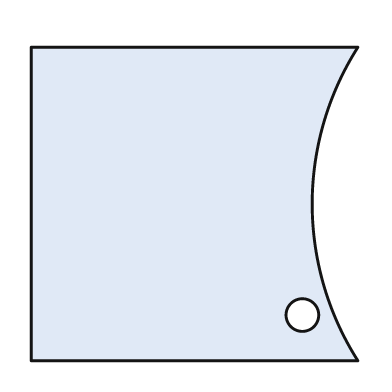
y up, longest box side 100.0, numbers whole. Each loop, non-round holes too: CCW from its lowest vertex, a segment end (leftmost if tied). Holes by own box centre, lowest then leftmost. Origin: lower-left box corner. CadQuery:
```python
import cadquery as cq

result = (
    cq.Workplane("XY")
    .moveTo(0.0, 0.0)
    .lineTo(100.0, 0.0)
    .threePointArc((86.0, 48.0), (100.0, 96.0))
    .lineTo(0.0, 96.0)
    .close()
    .moveTo(83.0, 14.0)
    .circle(5.0)
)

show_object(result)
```